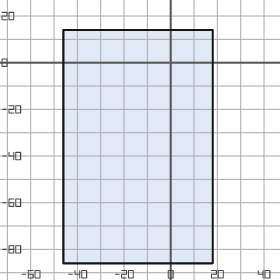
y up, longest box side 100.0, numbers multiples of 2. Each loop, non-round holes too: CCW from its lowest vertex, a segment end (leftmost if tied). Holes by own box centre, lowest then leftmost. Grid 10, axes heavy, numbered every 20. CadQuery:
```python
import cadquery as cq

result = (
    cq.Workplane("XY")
    .moveTo(-46.0, -86.0)
    .lineTo(18.0, -86.0)
    .lineTo(18.0, 14.0)
    .lineTo(-46.0, 14.0)
    .close()
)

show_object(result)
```